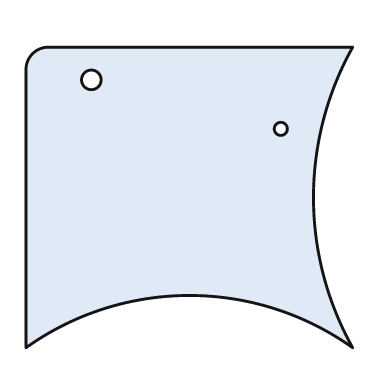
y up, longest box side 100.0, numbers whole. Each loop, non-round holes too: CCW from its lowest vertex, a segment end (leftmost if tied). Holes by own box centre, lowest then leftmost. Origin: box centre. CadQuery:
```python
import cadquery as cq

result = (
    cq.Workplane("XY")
    .moveTo(-50.0, -46.0)
    .threePointArc((0.0, -30.0), (50.0, -46.0))
    .threePointArc((38.0, 0.0), (50.0, 46.0))
    .lineTo(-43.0, 46.0)
    .threePointArc((-48.0, 44.0), (-50.0, 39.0))
    .close()
    .moveTo(28.0, 21.0)
    .circle(2.0)
    .moveTo(-30.0, 36.0)
    .circle(3.0)
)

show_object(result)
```